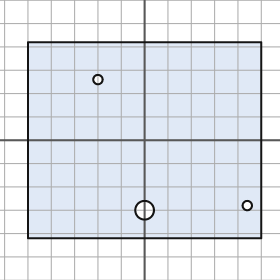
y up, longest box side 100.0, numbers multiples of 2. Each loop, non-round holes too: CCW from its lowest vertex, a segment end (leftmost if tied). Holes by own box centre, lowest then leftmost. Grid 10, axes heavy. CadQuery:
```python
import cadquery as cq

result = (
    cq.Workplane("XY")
    .moveTo(-50.0, -42.0)
    .lineTo(50.0, -42.0)
    .lineTo(50.0, 42.0)
    .lineTo(-50.0, 42.0)
    .close()
    .moveTo(0.0, -30.0)
    .circle(4.0)
    .moveTo(44.0, -28.0)
    .circle(2.0)
    .moveTo(-20.0, 26.0)
    .circle(2.0)
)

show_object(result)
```